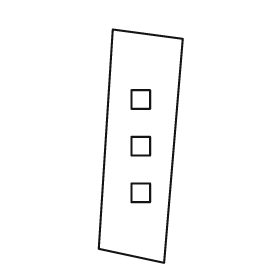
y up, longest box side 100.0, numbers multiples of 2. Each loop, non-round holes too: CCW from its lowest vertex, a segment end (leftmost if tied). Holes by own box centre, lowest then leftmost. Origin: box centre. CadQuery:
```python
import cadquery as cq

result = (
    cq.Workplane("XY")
    .moveTo(10.0, -50.0)
    .lineTo(18.0, 46.0)
    .lineTo(-12.0, 50.0)
    .lineTo(-18.0, -44.0)
    .close()
    .moveTo(-4.0, -24.0)
    .lineTo(4.0, -24.0)
    .lineTo(4.0, -16.0)
    .lineTo(-4.0, -16.0)
    .close()
    .moveTo(-4.0, -4.0)
    .lineTo(4.0, -4.0)
    .lineTo(4.0, 4.0)
    .lineTo(-4.0, 4.0)
    .close()
    .moveTo(-4.0, 16.0)
    .lineTo(4.0, 16.0)
    .lineTo(4.0, 24.0)
    .lineTo(-4.0, 24.0)
    .close()
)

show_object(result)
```